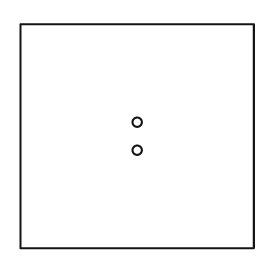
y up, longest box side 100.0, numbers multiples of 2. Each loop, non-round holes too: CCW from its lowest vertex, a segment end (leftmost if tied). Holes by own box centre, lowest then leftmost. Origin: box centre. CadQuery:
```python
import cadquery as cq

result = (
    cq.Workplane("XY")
    .moveTo(-50.0, -48.0)
    .lineTo(50.0, -48.0)
    .lineTo(50.0, 48.0)
    .lineTo(-50.0, 48.0)
    .close()
    .moveTo(0.0, -6.0)
    .circle(2.0)
    .moveTo(0.0, 6.0)
    .circle(2.0)
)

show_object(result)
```